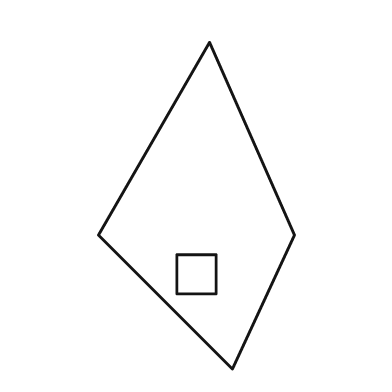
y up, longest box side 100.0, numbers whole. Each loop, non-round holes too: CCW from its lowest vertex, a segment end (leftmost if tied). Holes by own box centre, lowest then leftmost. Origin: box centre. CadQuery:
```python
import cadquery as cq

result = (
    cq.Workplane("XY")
    .moveTo(11.0, -50.0)
    .lineTo(30.0, -9.0)
    .lineTo(4.0, 50.0)
    .lineTo(-30.0, -9.0)
    .close()
    .moveTo(-6.0, -27.0)
    .lineTo(6.0, -27.0)
    .lineTo(6.0, -15.0)
    .lineTo(-6.0, -15.0)
    .close()
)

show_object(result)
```